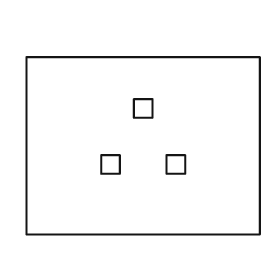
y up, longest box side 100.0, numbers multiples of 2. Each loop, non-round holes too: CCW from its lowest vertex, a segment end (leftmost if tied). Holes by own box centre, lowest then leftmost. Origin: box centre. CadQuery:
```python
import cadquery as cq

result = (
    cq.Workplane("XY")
    .moveTo(-50.0, -38.0)
    .lineTo(50.0, -38.0)
    .lineTo(50.0, 38.0)
    .lineTo(-50.0, 38.0)
    .close()
    .moveTo(-18.0, -12.0)
    .lineTo(-10.0, -12.0)
    .lineTo(-10.0, -4.0)
    .lineTo(-18.0, -4.0)
    .close()
    .moveTo(10.0, -12.0)
    .lineTo(18.0, -12.0)
    .lineTo(18.0, -4.0)
    .lineTo(10.0, -4.0)
    .close()
    .moveTo(-4.0, 12.0)
    .lineTo(4.0, 12.0)
    .lineTo(4.0, 20.0)
    .lineTo(-4.0, 20.0)
    .close()
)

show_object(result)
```